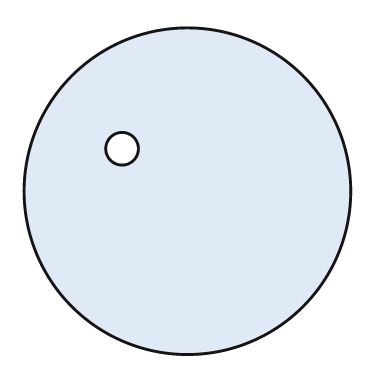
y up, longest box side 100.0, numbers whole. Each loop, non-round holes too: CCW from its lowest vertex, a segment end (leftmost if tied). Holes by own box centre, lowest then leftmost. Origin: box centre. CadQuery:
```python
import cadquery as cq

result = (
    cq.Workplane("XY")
    .moveTo(0.0, 0.0)
    .circle(50.0)
    .moveTo(-20.0, 13.0)
    .circle(5.0)
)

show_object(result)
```